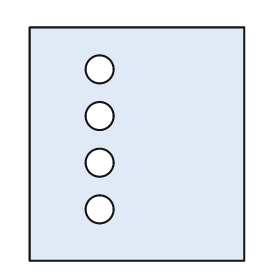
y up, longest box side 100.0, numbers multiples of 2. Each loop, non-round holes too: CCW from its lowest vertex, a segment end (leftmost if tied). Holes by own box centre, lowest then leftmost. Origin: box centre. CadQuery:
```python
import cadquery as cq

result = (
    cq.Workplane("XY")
    .moveTo(-46.0, -50.0)
    .lineTo(46.0, -50.0)
    .lineTo(46.0, 50.0)
    .lineTo(-46.0, 50.0)
    .close()
    .moveTo(-16.0, -28.0)
    .circle(6.0)
    .moveTo(-16.0, -8.0)
    .circle(6.0)
    .moveTo(-16.0, 12.0)
    .circle(6.0)
    .moveTo(-16.0, 32.0)
    .circle(6.0)
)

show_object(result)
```